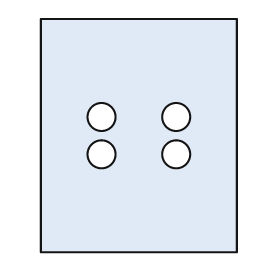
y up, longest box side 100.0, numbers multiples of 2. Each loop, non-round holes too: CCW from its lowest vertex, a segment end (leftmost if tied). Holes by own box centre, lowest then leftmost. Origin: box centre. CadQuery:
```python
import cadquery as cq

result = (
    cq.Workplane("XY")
    .moveTo(-42.0, -50.0)
    .lineTo(42.0, -50.0)
    .lineTo(42.0, 50.0)
    .lineTo(-42.0, 50.0)
    .close()
    .moveTo(-16.0, -8.0)
    .circle(6.0)
    .moveTo(16.0, -8.0)
    .circle(6.0)
    .moveTo(-16.0, 8.0)
    .circle(6.0)
    .moveTo(16.0, 8.0)
    .circle(6.0)
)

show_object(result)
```